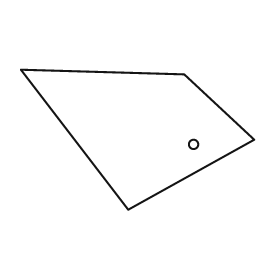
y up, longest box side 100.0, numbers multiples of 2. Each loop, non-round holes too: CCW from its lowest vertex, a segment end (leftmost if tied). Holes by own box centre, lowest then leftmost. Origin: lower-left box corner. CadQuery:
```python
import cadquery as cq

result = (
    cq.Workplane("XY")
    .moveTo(46.0, 0.0)
    .lineTo(100.0, 30.0)
    .lineTo(70.0, 58.0)
    .lineTo(0.0, 60.0)
    .close()
    .moveTo(74.0, 28.0)
    .circle(2.0)
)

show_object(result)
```